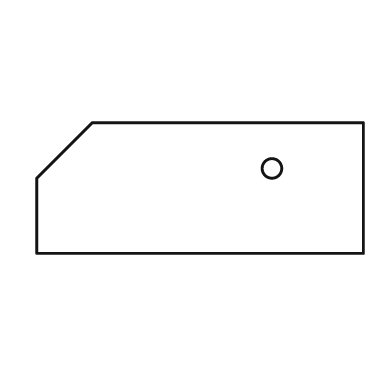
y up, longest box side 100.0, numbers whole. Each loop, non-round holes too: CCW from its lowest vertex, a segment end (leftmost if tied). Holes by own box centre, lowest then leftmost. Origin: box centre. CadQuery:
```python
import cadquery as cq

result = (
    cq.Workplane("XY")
    .moveTo(-50.0, -20.0)
    .lineTo(50.0, -20.0)
    .lineTo(50.0, 20.0)
    .lineTo(-33.0, 20.0)
    .lineTo(-50.0, 3.0)
    .close()
    .moveTo(22.0, 6.0)
    .circle(3.0)
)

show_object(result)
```